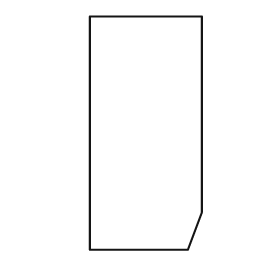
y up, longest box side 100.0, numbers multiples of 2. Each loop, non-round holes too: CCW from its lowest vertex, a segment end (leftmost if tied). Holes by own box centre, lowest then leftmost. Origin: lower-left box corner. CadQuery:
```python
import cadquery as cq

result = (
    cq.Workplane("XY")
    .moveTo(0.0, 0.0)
    .lineTo(42.0, 0.0)
    .lineTo(48.0, 16.0)
    .lineTo(48.0, 100.0)
    .lineTo(0.0, 100.0)
    .close()
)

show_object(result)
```